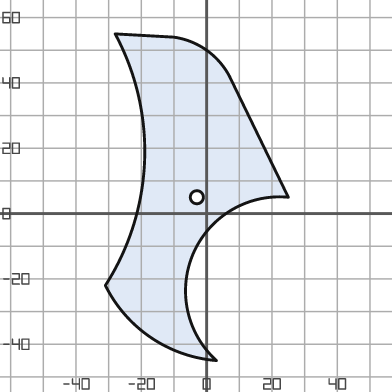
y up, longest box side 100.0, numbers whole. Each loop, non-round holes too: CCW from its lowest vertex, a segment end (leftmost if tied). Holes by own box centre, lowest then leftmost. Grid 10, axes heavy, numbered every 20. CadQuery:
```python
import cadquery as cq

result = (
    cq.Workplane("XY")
    .moveTo(3.0, -45.0)
    .threePointArc((-4.0, -12.0), (25.0, 5.0))
    .lineTo(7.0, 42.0)
    .threePointArc((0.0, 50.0), (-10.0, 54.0))
    .lineTo(-28.0, 55.0)
    .threePointArc((-19.0, 16.0), (-31.0, -22.0))
    .threePointArc((-17.0, -38.0), (3.0, -45.0))
    .close()
    .moveTo(-3.0, 5.0)
    .circle(2.0)
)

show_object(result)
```